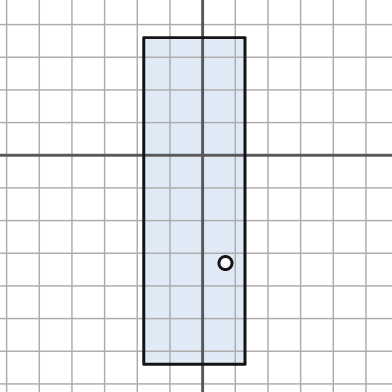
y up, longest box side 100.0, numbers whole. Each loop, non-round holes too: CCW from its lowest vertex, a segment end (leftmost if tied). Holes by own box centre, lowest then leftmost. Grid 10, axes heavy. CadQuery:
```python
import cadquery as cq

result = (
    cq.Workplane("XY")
    .moveTo(-18.0, -64.0)
    .lineTo(13.0, -64.0)
    .lineTo(13.0, 36.0)
    .lineTo(-18.0, 36.0)
    .close()
    .moveTo(7.0, -33.0)
    .circle(2.0)
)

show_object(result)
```